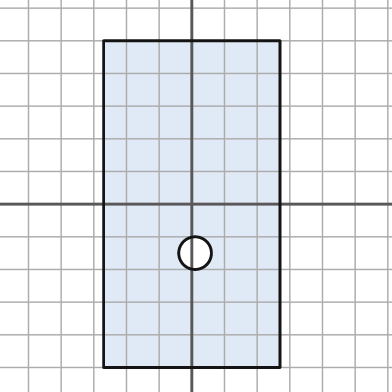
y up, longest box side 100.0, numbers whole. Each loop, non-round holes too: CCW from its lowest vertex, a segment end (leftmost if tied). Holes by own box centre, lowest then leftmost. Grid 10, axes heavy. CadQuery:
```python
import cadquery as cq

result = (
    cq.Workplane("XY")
    .moveTo(-27.0, -50.0)
    .lineTo(27.0, -50.0)
    .lineTo(27.0, 50.0)
    .lineTo(-27.0, 50.0)
    .close()
    .moveTo(1.0, -15.0)
    .circle(5.0)
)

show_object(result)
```